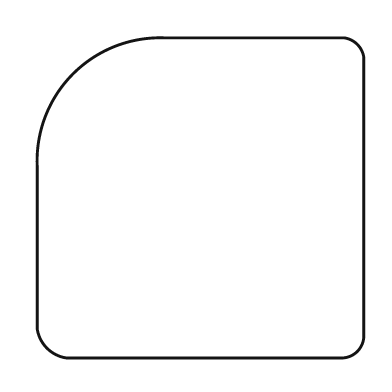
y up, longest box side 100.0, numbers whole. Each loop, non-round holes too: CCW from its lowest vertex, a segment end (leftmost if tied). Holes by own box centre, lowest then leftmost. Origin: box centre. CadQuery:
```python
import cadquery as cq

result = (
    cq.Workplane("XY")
    .moveTo(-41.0, -49.0)
    .lineTo(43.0, -49.0)
    .threePointArc((48.0, -47.0), (50.0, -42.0))
    .lineTo(50.0, 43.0)
    .threePointArc((48.0, 47.0), (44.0, 49.0))
    .lineTo(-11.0, 49.0)
    .threePointArc((-39.0, 38.0), (-50.0, 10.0))
    .lineTo(-50.0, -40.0)
    .threePointArc((-47.0, -46.0), (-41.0, -49.0))
    .close()
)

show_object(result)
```